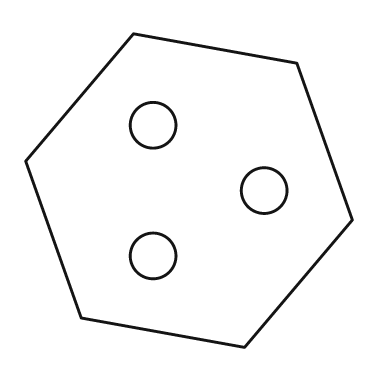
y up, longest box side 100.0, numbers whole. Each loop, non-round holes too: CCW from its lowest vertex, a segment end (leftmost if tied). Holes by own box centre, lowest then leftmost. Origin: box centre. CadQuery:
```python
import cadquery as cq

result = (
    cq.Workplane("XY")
    .moveTo(17.0, -48.0)
    .lineTo(50.0, -9.0)
    .lineTo(33.0, 39.0)
    .lineTo(-17.0, 48.0)
    .lineTo(-50.0, 9.0)
    .lineTo(-33.0, -39.0)
    .close()
    .moveTo(-11.0, -20.0)
    .circle(7.0)
    .moveTo(23.0, 0.0)
    .circle(7.0)
    .moveTo(-11.0, 20.0)
    .circle(7.0)
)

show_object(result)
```